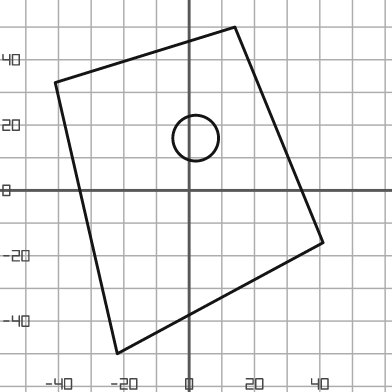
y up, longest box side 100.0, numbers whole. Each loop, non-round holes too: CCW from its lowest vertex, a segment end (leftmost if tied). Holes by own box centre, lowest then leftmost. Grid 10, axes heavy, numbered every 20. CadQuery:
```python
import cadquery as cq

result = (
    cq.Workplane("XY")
    .moveTo(-22.0, -50.0)
    .lineTo(41.0, -16.0)
    .lineTo(14.0, 50.0)
    .lineTo(-41.0, 33.0)
    .close()
    .moveTo(2.0, 16.0)
    .circle(7.0)
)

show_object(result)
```